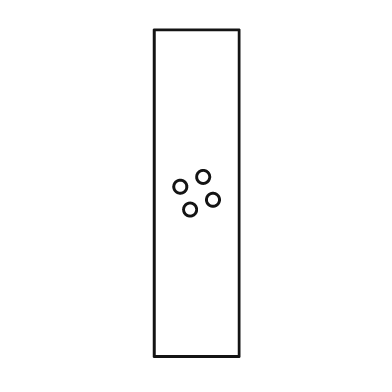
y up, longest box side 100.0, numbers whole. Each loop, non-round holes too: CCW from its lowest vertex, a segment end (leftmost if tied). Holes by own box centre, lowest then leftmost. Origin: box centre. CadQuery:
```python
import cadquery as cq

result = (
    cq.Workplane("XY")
    .moveTo(-13.0, -50.0)
    .lineTo(13.0, -50.0)
    .lineTo(13.0, 50.0)
    .lineTo(-13.0, 50.0)
    .close()
    .moveTo(-2.0, -5.0)
    .circle(2.0)
    .moveTo(5.0, -2.0)
    .circle(2.0)
    .moveTo(-5.0, 2.0)
    .circle(2.0)
    .moveTo(2.0, 5.0)
    .circle(2.0)
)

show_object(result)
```